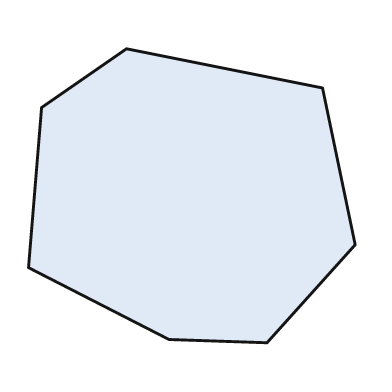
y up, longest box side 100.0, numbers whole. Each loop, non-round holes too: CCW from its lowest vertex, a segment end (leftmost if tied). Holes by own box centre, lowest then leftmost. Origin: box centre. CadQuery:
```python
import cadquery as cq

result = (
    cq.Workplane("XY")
    .moveTo(23.0, -45.0)
    .lineTo(50.0, -15.0)
    .lineTo(40.0, 33.0)
    .lineTo(-20.0, 45.0)
    .lineTo(-46.0, 27.0)
    .lineTo(-50.0, -22.0)
    .lineTo(-7.0, -44.0)
    .close()
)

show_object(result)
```